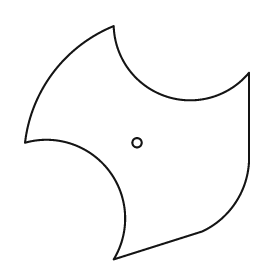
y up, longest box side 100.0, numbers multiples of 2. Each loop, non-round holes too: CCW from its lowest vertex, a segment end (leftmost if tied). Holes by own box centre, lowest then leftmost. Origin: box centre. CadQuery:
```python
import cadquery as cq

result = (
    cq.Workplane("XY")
    .moveTo(-10.0, -50.0)
    .lineTo(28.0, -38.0)
    .threePointArc((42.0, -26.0), (48.0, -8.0))
    .lineTo(48.0, 30.0)
    .threePointArc((12.0, 20.0), (-10.0, 50.0))
    .threePointArc((-36.0, 30.0), (-48.0, 0.0))
    .threePointArc((-12.0, -12.0), (-10.0, -50.0))
    .close()
    .moveTo(0.0, 0.0)
    .circle(2.0)
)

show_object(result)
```